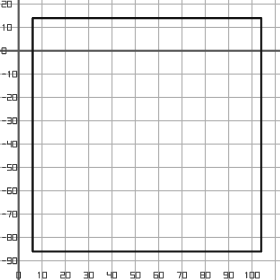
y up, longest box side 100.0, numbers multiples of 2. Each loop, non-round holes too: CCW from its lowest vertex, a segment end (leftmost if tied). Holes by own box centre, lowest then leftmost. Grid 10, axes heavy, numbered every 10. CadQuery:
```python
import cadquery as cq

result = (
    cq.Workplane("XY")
    .moveTo(6.0, -86.0)
    .lineTo(104.0, -86.0)
    .lineTo(104.0, 14.0)
    .lineTo(6.0, 14.0)
    .close()
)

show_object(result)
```